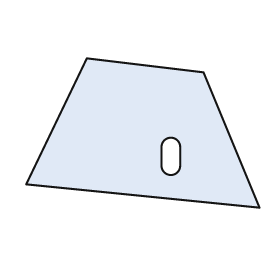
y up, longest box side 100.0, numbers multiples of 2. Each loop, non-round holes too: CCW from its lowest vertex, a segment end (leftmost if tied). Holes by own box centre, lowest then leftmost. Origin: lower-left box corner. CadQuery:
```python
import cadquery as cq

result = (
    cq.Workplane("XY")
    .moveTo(100.0, 0.0)
    .lineTo(76.0, 58.0)
    .lineTo(26.0, 64.0)
    .lineTo(0.0, 10.0)
    .close()
    .moveTo(58.0, 18.0)
    .threePointArc((62.0, 14.0), (66.0, 18.0))
    .lineTo(66.0, 26.0)
    .threePointArc((62.0, 30.0), (58.0, 26.0))
    .close()
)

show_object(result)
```